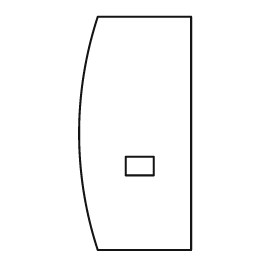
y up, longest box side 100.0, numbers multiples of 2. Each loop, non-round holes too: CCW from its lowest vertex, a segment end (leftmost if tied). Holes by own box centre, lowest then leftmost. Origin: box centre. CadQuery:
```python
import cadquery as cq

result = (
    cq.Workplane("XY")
    .moveTo(-16.0, -50.0)
    .lineTo(24.0, -50.0)
    .lineTo(24.0, 50.0)
    .lineTo(-16.0, 50.0)
    .threePointArc((-24.0, 0.0), (-16.0, -50.0))
    .close()
    .moveTo(-4.0, -18.0)
    .lineTo(8.0, -18.0)
    .lineTo(8.0, -10.0)
    .lineTo(-4.0, -10.0)
    .close()
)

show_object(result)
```